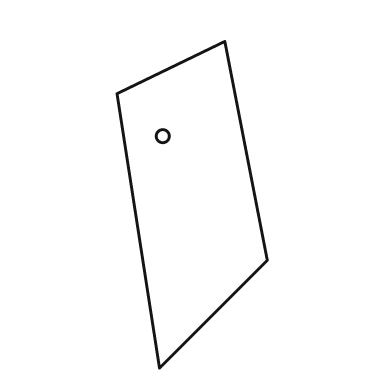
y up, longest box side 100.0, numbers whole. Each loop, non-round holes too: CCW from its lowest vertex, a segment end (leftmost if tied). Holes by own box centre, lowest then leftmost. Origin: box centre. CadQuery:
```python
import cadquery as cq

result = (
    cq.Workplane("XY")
    .moveTo(-10.0, -50.0)
    .lineTo(23.0, -17.0)
    .lineTo(10.0, 50.0)
    .lineTo(-23.0, 34.0)
    .close()
    .moveTo(-9.0, 21.0)
    .circle(2.0)
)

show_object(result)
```